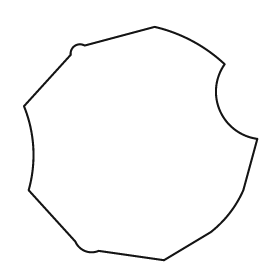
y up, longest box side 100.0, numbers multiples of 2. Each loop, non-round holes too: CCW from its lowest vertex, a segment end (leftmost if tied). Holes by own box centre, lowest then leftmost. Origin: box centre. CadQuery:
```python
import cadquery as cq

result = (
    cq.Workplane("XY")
    .moveTo(10.0, -50.0)
    .lineTo(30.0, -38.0)
    .threePointArc((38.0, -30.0), (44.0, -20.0))
    .lineTo(50.0, 2.0)
    .threePointArc((34.0, 14.0), (36.0, 34.0))
    .threePointArc((22.0, 44.0), (6.0, 50.0))
    .lineTo(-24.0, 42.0)
    .threePointArc((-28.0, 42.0), (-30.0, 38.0))
    .lineTo(-50.0, 16.0)
    .threePointArc((-46.0, -2.0), (-48.0, -20.0))
    .lineTo(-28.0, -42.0)
    .threePointArc((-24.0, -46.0), (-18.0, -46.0))
    .close()
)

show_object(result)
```